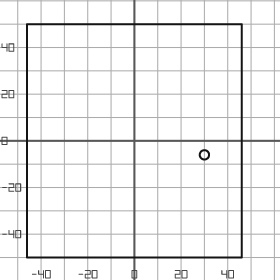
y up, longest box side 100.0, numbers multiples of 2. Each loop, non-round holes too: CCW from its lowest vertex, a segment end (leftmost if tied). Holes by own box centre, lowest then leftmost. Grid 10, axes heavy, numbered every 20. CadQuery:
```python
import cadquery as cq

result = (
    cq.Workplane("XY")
    .moveTo(-46.0, -50.0)
    .lineTo(46.0, -50.0)
    .lineTo(46.0, 50.0)
    .lineTo(-46.0, 50.0)
    .close()
    .moveTo(30.0, -6.0)
    .circle(2.0)
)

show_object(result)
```